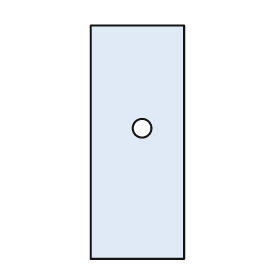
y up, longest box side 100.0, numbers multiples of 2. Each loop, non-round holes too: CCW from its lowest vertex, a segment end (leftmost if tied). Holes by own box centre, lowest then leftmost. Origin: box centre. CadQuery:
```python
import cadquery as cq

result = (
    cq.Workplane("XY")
    .moveTo(-20.0, -50.0)
    .lineTo(20.0, -50.0)
    .lineTo(20.0, 50.0)
    .lineTo(-20.0, 50.0)
    .close()
    .moveTo(2.0, 6.0)
    .circle(4.0)
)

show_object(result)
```